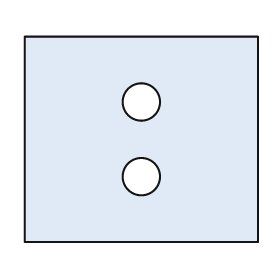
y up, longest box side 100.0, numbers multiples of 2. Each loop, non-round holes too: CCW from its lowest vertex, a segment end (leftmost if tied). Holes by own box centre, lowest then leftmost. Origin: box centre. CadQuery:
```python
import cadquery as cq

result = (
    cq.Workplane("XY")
    .moveTo(-50.0, -44.0)
    .lineTo(50.0, -44.0)
    .lineTo(50.0, 44.0)
    .lineTo(-50.0, 44.0)
    .close()
    .moveTo(0.0, -16.0)
    .circle(8.0)
    .moveTo(0.0, 16.0)
    .circle(8.0)
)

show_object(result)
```